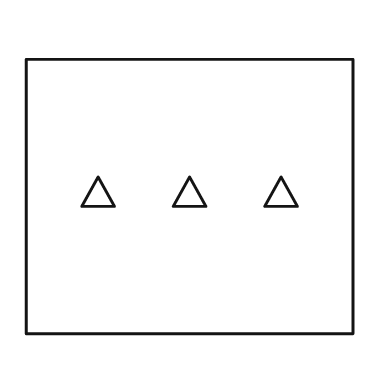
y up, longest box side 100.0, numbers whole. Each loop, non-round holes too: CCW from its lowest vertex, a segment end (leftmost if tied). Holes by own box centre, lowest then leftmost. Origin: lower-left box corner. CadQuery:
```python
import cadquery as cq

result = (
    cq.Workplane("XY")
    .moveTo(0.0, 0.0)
    .lineTo(100.0, 0.0)
    .lineTo(100.0, 84.0)
    .lineTo(0.0, 84.0)
    .close()
    .moveTo(17.0, 39.0)
    .lineTo(27.0, 39.0)
    .lineTo(22.0, 48.0)
    .close()
    .moveTo(45.0, 39.0)
    .lineTo(55.0, 39.0)
    .lineTo(50.0, 48.0)
    .close()
    .moveTo(73.0, 39.0)
    .lineTo(83.0, 39.0)
    .lineTo(78.0, 48.0)
    .close()
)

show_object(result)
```